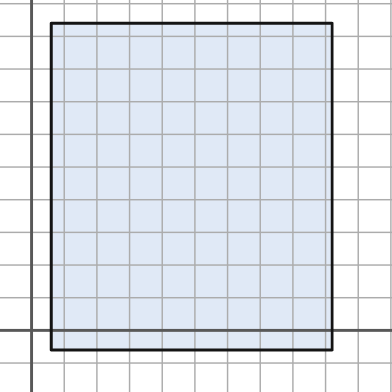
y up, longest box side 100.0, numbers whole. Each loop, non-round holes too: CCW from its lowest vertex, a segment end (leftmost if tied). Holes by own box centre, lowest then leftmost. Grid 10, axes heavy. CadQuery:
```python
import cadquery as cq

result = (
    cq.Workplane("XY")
    .moveTo(6.0, -6.0)
    .lineTo(92.0, -6.0)
    .lineTo(92.0, 94.0)
    .lineTo(6.0, 94.0)
    .close()
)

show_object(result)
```